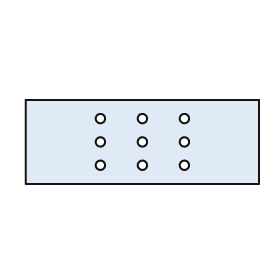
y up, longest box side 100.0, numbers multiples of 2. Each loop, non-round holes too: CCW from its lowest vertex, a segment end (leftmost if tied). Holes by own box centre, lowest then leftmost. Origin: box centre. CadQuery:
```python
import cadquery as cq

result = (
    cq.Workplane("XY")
    .moveTo(-50.0, -18.0)
    .lineTo(50.0, -18.0)
    .lineTo(50.0, 18.0)
    .lineTo(-50.0, 18.0)
    .close()
    .moveTo(-18.0, -10.0)
    .circle(2.0)
    .moveTo(0.0, -10.0)
    .circle(2.0)
    .moveTo(18.0, -10.0)
    .circle(2.0)
    .moveTo(-18.0, 0.0)
    .circle(2.0)
    .moveTo(0.0, 0.0)
    .circle(2.0)
    .moveTo(18.0, 0.0)
    .circle(2.0)
    .moveTo(-18.0, 10.0)
    .circle(2.0)
    .moveTo(0.0, 10.0)
    .circle(2.0)
    .moveTo(18.0, 10.0)
    .circle(2.0)
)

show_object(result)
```